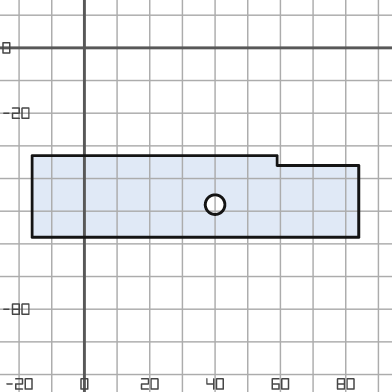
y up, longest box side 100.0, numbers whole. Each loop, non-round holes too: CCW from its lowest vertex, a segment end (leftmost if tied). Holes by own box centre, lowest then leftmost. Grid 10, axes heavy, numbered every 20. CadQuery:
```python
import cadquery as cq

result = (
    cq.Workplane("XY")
    .moveTo(-16.0, -58.0)
    .lineTo(84.0, -58.0)
    .lineTo(84.0, -36.0)
    .lineTo(59.0, -36.0)
    .lineTo(59.0, -33.0)
    .lineTo(-16.0, -33.0)
    .close()
    .moveTo(40.0, -48.0)
    .circle(3.0)
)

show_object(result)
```